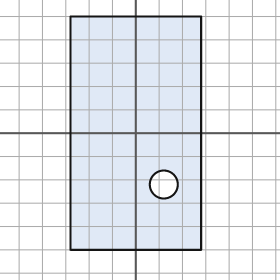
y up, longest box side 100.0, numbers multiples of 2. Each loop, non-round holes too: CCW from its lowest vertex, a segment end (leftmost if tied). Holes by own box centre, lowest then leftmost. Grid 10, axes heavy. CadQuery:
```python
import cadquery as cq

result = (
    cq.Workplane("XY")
    .moveTo(-28.0, -50.0)
    .lineTo(28.0, -50.0)
    .lineTo(28.0, 50.0)
    .lineTo(-28.0, 50.0)
    .close()
    .moveTo(12.0, -22.0)
    .circle(6.0)
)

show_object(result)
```